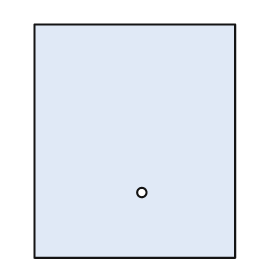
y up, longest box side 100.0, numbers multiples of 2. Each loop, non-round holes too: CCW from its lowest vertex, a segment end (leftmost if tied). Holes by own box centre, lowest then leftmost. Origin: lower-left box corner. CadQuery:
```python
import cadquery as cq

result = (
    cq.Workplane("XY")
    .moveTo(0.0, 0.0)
    .lineTo(86.0, 0.0)
    .lineTo(86.0, 100.0)
    .lineTo(0.0, 100.0)
    .close()
    .moveTo(46.0, 28.0)
    .circle(2.0)
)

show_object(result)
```